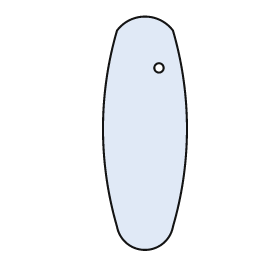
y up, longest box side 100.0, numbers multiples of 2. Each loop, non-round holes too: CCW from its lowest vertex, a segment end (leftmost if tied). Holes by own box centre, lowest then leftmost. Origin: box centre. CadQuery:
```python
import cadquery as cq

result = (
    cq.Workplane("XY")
    .moveTo(-12.0, -40.0)
    .threePointArc((0.0, -50.0), (12.0, -40.0))
    .threePointArc((18.0, 2.0), (12.0, 44.0))
    .threePointArc((0.0, 50.0), (-12.0, 44.0))
    .threePointArc((-18.0, 2.0), (-12.0, -40.0))
    .close()
    .moveTo(6.0, 28.0)
    .circle(2.0)
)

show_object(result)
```